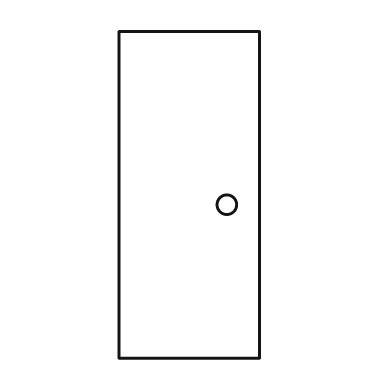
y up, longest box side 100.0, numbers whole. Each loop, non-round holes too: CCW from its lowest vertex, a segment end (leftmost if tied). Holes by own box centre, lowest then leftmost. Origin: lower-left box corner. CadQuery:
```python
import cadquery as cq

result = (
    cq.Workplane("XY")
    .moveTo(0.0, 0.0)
    .lineTo(43.0, 0.0)
    .lineTo(43.0, 100.0)
    .lineTo(0.0, 100.0)
    .close()
    .moveTo(33.0, 47.0)
    .circle(3.0)
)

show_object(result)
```